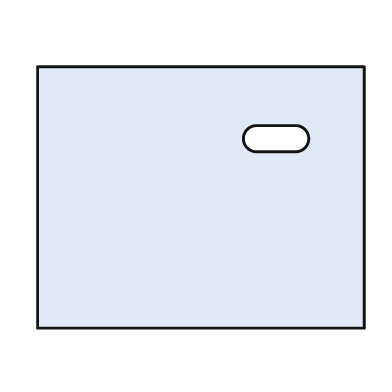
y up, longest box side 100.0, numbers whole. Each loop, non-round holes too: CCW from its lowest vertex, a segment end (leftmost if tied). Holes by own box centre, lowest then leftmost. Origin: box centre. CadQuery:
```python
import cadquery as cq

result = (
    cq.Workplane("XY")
    .moveTo(-50.0, -40.0)
    .lineTo(50.0, -40.0)
    .lineTo(50.0, 40.0)
    .lineTo(-50.0, 40.0)
    .close()
    .moveTo(17.0, 14.0)
    .lineTo(29.0, 14.0)
    .threePointArc((33.0, 18.0), (29.0, 22.0))
    .lineTo(17.0, 22.0)
    .threePointArc((13.0, 18.0), (17.0, 14.0))
    .close()
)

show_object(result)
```